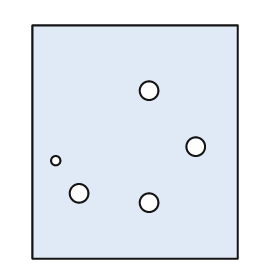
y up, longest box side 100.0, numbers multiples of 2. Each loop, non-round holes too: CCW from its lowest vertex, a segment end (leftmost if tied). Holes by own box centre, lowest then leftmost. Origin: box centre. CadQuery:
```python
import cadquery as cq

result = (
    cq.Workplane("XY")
    .moveTo(-44.0, -50.0)
    .lineTo(44.0, -50.0)
    .lineTo(44.0, 50.0)
    .lineTo(-44.0, 50.0)
    .close()
    .moveTo(6.0, -26.0)
    .circle(4.0)
    .moveTo(-24.0, -22.0)
    .circle(4.0)
    .moveTo(-34.0, -8.0)
    .circle(2.0)
    .moveTo(26.0, -2.0)
    .circle(4.0)
    .moveTo(6.0, 22.0)
    .circle(4.0)
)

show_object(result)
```